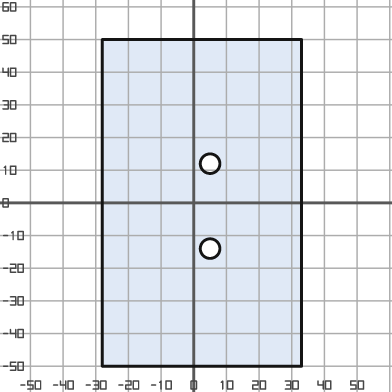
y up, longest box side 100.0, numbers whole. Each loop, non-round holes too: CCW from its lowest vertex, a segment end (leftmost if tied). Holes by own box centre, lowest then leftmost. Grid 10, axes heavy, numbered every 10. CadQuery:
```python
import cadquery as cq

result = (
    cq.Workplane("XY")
    .moveTo(-28.0, -50.0)
    .lineTo(33.0, -50.0)
    .lineTo(33.0, 50.0)
    .lineTo(-28.0, 50.0)
    .close()
    .moveTo(5.0, -14.0)
    .circle(3.0)
    .moveTo(5.0, 12.0)
    .circle(3.0)
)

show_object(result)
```